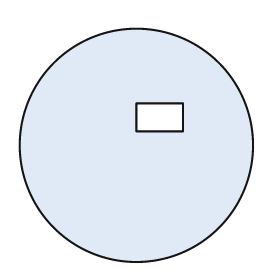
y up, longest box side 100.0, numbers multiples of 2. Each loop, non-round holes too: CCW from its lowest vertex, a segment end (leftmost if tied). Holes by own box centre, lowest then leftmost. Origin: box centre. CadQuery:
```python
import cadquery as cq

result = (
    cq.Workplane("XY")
    .moveTo(0.0, 0.0)
    .circle(50.0)
    .moveTo(0.0, 6.0)
    .lineTo(20.0, 6.0)
    .lineTo(20.0, 18.0)
    .lineTo(0.0, 18.0)
    .close()
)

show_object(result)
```